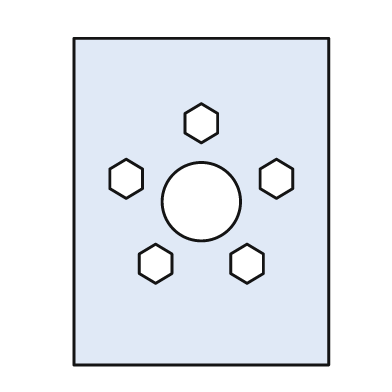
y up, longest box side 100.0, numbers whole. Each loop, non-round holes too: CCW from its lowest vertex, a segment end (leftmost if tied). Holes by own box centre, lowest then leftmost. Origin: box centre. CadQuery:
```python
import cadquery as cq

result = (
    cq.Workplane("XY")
    .moveTo(-39.0, -50.0)
    .lineTo(39.0, -50.0)
    .lineTo(39.0, 50.0)
    .lineTo(-39.0, 50.0)
    .close()
    .moveTo(-14.0, -25.0)
    .lineTo(-9.0, -22.0)
    .lineTo(-9.0, -16.0)
    .lineTo(-14.0, -13.0)
    .lineTo(-19.0, -16.0)
    .lineTo(-19.0, -22.0)
    .close()
    .moveTo(14.0, -25.0)
    .lineTo(19.0, -22.0)
    .lineTo(19.0, -16.0)
    .lineTo(14.0, -13.0)
    .lineTo(9.0, -16.0)
    .lineTo(9.0, -22.0)
    .close()
    .moveTo(0.0, 0.0)
    .circle(12.0)
    .moveTo(-23.0, 1.0)
    .lineTo(-18.0, 4.0)
    .lineTo(-18.0, 10.0)
    .lineTo(-23.0, 13.0)
    .lineTo(-28.0, 10.0)
    .lineTo(-28.0, 4.0)
    .close()
    .moveTo(23.0, 1.0)
    .lineTo(28.0, 4.0)
    .lineTo(28.0, 10.0)
    .lineTo(23.0, 13.0)
    .lineTo(18.0, 10.0)
    .lineTo(18.0, 4.0)
    .close()
    .moveTo(0.0, 18.0)
    .lineTo(5.0, 21.0)
    .lineTo(5.0, 27.0)
    .lineTo(0.0, 30.0)
    .lineTo(-5.0, 27.0)
    .lineTo(-5.0, 21.0)
    .close()
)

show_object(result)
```